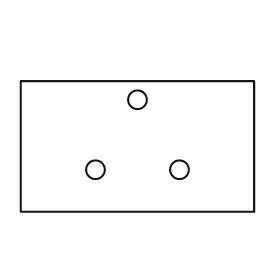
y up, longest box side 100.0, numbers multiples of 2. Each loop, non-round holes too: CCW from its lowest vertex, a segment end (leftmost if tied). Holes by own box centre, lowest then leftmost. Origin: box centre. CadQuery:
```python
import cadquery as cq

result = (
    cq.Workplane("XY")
    .moveTo(-50.0, -28.0)
    .lineTo(50.0, -28.0)
    .lineTo(50.0, 28.0)
    .lineTo(-50.0, 28.0)
    .close()
    .moveTo(-18.0, -10.0)
    .circle(4.0)
    .moveTo(18.0, -10.0)
    .circle(4.0)
    .moveTo(0.0, 20.0)
    .circle(4.0)
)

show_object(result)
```